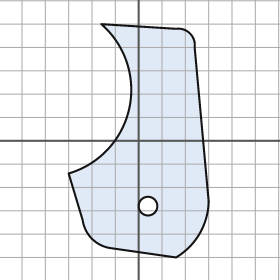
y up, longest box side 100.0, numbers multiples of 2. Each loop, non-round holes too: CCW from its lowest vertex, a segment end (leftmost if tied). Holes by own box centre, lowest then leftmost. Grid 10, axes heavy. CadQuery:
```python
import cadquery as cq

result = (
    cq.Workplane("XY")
    .moveTo(16.0, -50.0)
    .threePointArc((26.0, -40.0), (30.0, -26.0))
    .lineTo(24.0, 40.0)
    .threePointArc((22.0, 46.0), (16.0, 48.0))
    .lineTo(-16.0, 50.0)
    .threePointArc((-4.0, 14.0), (-30.0, -14.0))
    .lineTo(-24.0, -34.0)
    .threePointArc((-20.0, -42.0), (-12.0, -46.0))
    .close()
    .moveTo(4.0, -28.0)
    .circle(4.0)
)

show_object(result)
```